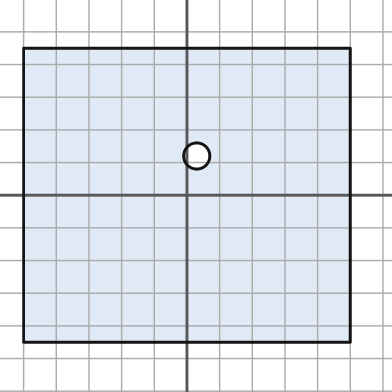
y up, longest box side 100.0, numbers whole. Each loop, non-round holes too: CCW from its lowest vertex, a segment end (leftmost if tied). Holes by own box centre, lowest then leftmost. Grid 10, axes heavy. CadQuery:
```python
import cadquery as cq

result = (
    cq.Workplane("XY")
    .moveTo(-50.0, -45.0)
    .lineTo(50.0, -45.0)
    .lineTo(50.0, 45.0)
    .lineTo(-50.0, 45.0)
    .close()
    .moveTo(3.0, 12.0)
    .circle(4.0)
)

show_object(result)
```